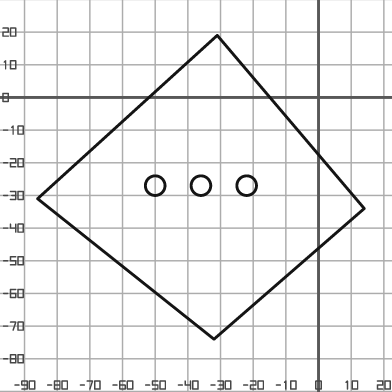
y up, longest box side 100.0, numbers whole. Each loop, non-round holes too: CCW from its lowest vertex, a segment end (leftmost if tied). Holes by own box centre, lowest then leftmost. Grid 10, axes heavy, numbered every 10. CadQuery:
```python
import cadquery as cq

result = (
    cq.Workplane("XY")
    .moveTo(-32.0, -74.0)
    .lineTo(14.0, -34.0)
    .lineTo(-31.0, 19.0)
    .lineTo(-86.0, -31.0)
    .close()
    .moveTo(-50.0, -27.0)
    .circle(3.0)
    .moveTo(-36.0, -27.0)
    .circle(3.0)
    .moveTo(-22.0, -27.0)
    .circle(3.0)
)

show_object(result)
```